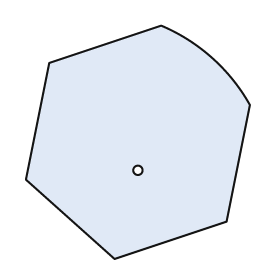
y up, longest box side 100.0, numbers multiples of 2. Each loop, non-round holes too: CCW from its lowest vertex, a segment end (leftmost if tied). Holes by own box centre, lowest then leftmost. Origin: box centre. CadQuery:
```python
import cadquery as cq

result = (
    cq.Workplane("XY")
    .moveTo(-10.0, -50.0)
    .lineTo(38.0, -34.0)
    .lineTo(48.0, 16.0)
    .threePointArc((32.0, 36.0), (10.0, 50.0))
    .lineTo(-38.0, 34.0)
    .lineTo(-48.0, -16.0)
    .close()
    .moveTo(0.0, -12.0)
    .circle(2.0)
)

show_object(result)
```